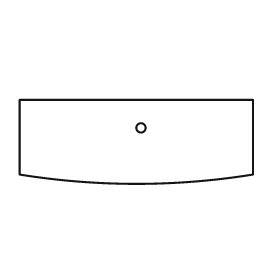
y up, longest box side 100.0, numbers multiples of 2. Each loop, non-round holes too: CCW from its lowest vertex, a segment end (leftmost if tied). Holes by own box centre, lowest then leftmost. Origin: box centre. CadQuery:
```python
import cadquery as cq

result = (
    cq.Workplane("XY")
    .moveTo(-50.0, -14.0)
    .threePointArc((0.0, -18.0), (50.0, -14.0))
    .lineTo(50.0, 18.0)
    .lineTo(-50.0, 18.0)
    .close()
    .moveTo(2.0, 6.0)
    .circle(2.0)
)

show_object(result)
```